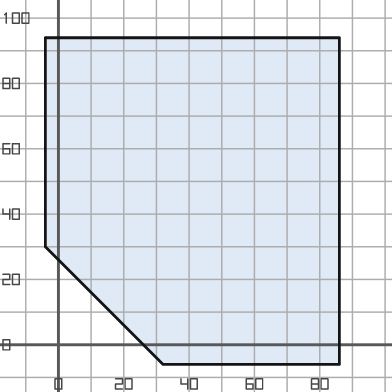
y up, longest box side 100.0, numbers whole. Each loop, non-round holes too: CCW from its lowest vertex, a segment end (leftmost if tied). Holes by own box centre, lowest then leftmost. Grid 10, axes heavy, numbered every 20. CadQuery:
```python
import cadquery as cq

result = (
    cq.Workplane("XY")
    .moveTo(32.0, -6.0)
    .lineTo(86.0, -6.0)
    .lineTo(86.0, 94.0)
    .lineTo(-4.0, 94.0)
    .lineTo(-4.0, 30.0)
    .close()
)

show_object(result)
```